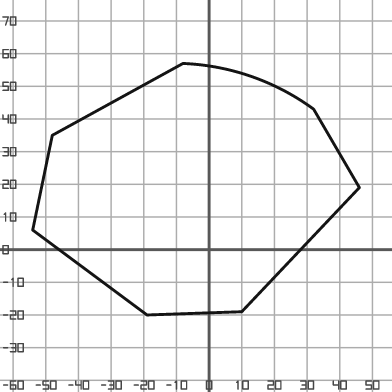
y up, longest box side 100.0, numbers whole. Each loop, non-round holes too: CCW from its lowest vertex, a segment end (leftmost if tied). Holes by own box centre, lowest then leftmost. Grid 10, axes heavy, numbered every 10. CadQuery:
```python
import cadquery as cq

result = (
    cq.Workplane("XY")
    .moveTo(-19.0, -20.0)
    .lineTo(10.0, -19.0)
    .lineTo(46.0, 19.0)
    .lineTo(32.0, 43.0)
    .threePointArc((13.0, 53.0), (-8.0, 57.0))
    .lineTo(-48.0, 35.0)
    .lineTo(-54.0, 6.0)
    .close()
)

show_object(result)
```